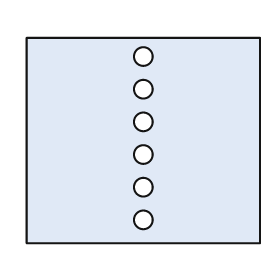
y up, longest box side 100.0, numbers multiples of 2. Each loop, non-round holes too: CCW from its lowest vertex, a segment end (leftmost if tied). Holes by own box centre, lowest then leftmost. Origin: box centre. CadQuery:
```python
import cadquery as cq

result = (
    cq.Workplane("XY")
    .moveTo(-50.0, -44.0)
    .lineTo(50.0, -44.0)
    .lineTo(50.0, 44.0)
    .lineTo(-50.0, 44.0)
    .close()
    .moveTo(0.0, -34.0)
    .circle(4.0)
    .moveTo(0.0, -20.0)
    .circle(4.0)
    .moveTo(0.0, -6.0)
    .circle(4.0)
    .moveTo(0.0, 8.0)
    .circle(4.0)
    .moveTo(0.0, 22.0)
    .circle(4.0)
    .moveTo(0.0, 36.0)
    .circle(4.0)
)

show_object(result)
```